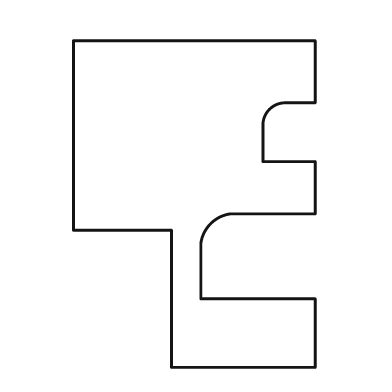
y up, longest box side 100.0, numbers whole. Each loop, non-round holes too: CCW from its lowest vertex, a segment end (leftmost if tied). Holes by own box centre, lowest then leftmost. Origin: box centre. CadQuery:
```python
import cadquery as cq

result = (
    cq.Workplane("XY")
    .moveTo(-7.0, -50.0)
    .lineTo(37.0, -50.0)
    .lineTo(37.0, -29.0)
    .lineTo(2.0, -29.0)
    .lineTo(2.0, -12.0)
    .threePointArc((5.0, -6.0), (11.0, -3.0))
    .lineTo(37.0, -3.0)
    .lineTo(37.0, 13.0)
    .lineTo(21.0, 13.0)
    .lineTo(21.0, 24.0)
    .threePointArc((23.0, 29.0), (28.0, 31.0))
    .lineTo(37.0, 31.0)
    .lineTo(37.0, 50.0)
    .lineTo(-37.0, 50.0)
    .lineTo(-37.0, -8.0)
    .lineTo(-7.0, -8.0)
    .close()
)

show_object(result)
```